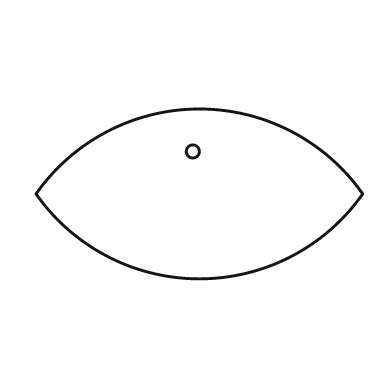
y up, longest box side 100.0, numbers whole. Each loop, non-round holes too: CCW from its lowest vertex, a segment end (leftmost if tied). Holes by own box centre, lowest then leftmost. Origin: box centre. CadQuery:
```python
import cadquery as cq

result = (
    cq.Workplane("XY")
    .moveTo(-50.0, 0.0)
    .threePointArc((0.0, -26.0), (50.0, 0.0))
    .threePointArc((0.0, 26.0), (-50.0, 0.0))
    .close()
    .moveTo(-2.0, 13.0)
    .circle(2.0)
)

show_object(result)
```